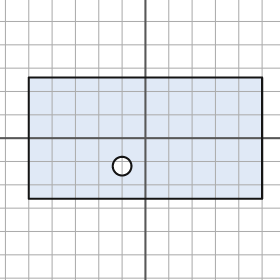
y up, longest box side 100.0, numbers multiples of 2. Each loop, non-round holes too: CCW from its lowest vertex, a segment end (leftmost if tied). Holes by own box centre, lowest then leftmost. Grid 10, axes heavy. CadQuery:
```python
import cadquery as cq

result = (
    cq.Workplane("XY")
    .moveTo(-50.0, -26.0)
    .lineTo(50.0, -26.0)
    .lineTo(50.0, 26.0)
    .lineTo(-50.0, 26.0)
    .close()
    .moveTo(-10.0, -12.0)
    .circle(4.0)
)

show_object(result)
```